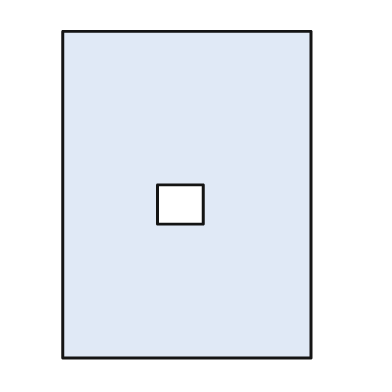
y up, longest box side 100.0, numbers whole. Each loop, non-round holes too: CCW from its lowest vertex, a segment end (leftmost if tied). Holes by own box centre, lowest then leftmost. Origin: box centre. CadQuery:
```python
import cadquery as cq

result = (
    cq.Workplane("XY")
    .moveTo(-38.0, -50.0)
    .lineTo(38.0, -50.0)
    .lineTo(38.0, 50.0)
    .lineTo(-38.0, 50.0)
    .close()
    .moveTo(-9.0, -9.0)
    .lineTo(5.0, -9.0)
    .lineTo(5.0, 3.0)
    .lineTo(-9.0, 3.0)
    .close()
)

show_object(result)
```